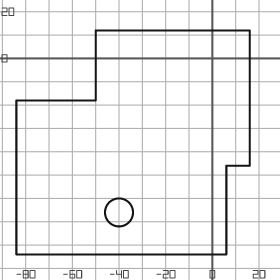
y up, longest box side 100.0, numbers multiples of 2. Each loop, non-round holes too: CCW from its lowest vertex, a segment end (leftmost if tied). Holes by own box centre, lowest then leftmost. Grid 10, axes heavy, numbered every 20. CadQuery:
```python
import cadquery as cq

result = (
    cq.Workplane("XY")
    .moveTo(-84.0, -84.0)
    .lineTo(6.0, -84.0)
    .lineTo(6.0, -46.0)
    .lineTo(16.0, -46.0)
    .lineTo(16.0, 12.0)
    .lineTo(-50.0, 12.0)
    .lineTo(-50.0, -18.0)
    .lineTo(-84.0, -18.0)
    .close()
    .moveTo(-40.0, -66.0)
    .circle(6.0)
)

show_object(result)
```